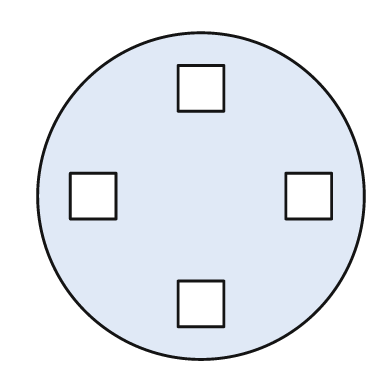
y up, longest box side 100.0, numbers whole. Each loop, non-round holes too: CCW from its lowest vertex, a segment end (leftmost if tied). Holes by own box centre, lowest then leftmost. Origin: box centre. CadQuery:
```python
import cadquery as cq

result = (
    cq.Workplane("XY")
    .moveTo(0.0, 0.0)
    .circle(50.0)
    .moveTo(-7.0, -40.0)
    .lineTo(7.0, -40.0)
    .lineTo(7.0, -26.0)
    .lineTo(-7.0, -26.0)
    .close()
    .moveTo(-40.0, -7.0)
    .lineTo(-26.0, -7.0)
    .lineTo(-26.0, 7.0)
    .lineTo(-40.0, 7.0)
    .close()
    .moveTo(26.0, -7.0)
    .lineTo(40.0, -7.0)
    .lineTo(40.0, 7.0)
    .lineTo(26.0, 7.0)
    .close()
    .moveTo(-7.0, 26.0)
    .lineTo(7.0, 26.0)
    .lineTo(7.0, 40.0)
    .lineTo(-7.0, 40.0)
    .close()
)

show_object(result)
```